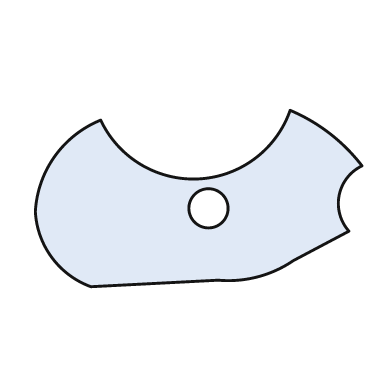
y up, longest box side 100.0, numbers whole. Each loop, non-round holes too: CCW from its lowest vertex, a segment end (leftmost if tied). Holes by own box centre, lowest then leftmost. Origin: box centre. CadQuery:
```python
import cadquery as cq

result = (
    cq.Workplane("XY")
    .moveTo(-33.0, -27.0)
    .lineTo(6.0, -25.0)
    .threePointArc((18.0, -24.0), (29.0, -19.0))
    .lineTo(46.0, -10.0)
    .threePointArc((43.0, 1.0), (50.0, 10.0))
    .threePointArc((40.0, 20.0), (28.0, 27.0))
    .threePointArc((0.0, 6.0), (-30.0, 24.0))
    .threePointArc((-44.0, 13.0), (-50.0, -4.0))
    .threePointArc((-45.0, -18.0), (-33.0, -27.0))
    .close()
    .moveTo(3.0, -3.0)
    .circle(6.0)
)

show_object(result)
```